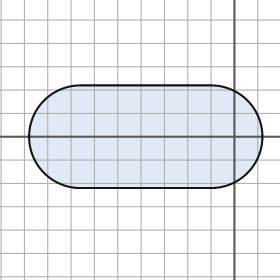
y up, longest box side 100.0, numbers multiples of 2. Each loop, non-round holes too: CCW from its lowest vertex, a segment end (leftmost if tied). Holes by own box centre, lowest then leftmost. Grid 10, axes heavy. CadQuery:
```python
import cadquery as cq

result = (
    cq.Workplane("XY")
    .moveTo(-66.0, -22.0)
    .lineTo(-10.0, -22.0)
    .threePointArc((12.0, 0.0), (-10.0, 22.0))
    .lineTo(-66.0, 22.0)
    .threePointArc((-88.0, 0.0), (-66.0, -22.0))
    .close()
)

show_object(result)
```